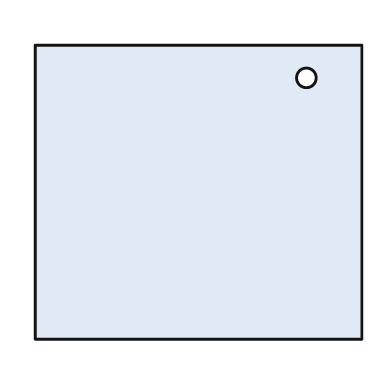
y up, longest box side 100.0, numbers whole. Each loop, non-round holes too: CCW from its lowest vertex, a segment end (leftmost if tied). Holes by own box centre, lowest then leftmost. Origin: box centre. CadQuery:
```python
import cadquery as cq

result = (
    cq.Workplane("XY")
    .moveTo(-50.0, -45.0)
    .lineTo(50.0, -45.0)
    .lineTo(50.0, 45.0)
    .lineTo(-50.0, 45.0)
    .close()
    .moveTo(33.0, 35.0)
    .circle(3.0)
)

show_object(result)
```